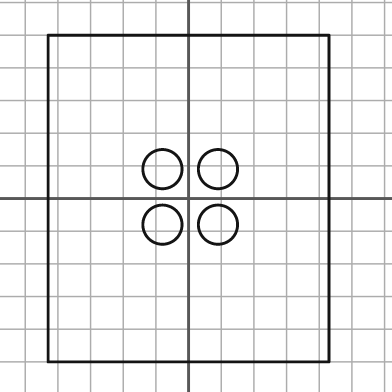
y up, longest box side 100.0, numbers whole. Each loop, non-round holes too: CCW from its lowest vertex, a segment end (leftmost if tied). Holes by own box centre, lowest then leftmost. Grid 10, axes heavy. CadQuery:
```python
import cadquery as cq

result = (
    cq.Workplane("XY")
    .moveTo(-43.0, -50.0)
    .lineTo(43.0, -50.0)
    .lineTo(43.0, 50.0)
    .lineTo(-43.0, 50.0)
    .close()
    .moveTo(-8.0, -8.0)
    .circle(6.0)
    .moveTo(9.0, -8.0)
    .circle(6.0)
    .moveTo(-8.0, 9.0)
    .circle(6.0)
    .moveTo(9.0, 9.0)
    .circle(6.0)
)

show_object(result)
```